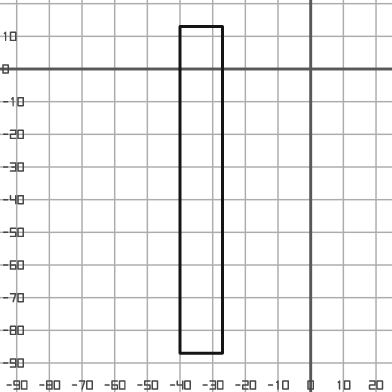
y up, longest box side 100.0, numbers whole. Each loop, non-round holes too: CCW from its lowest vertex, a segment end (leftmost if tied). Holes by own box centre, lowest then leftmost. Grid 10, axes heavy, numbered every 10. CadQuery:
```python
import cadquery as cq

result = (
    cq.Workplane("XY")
    .moveTo(-40.0, -87.0)
    .lineTo(-27.0, -87.0)
    .lineTo(-27.0, 13.0)
    .lineTo(-40.0, 13.0)
    .close()
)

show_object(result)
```